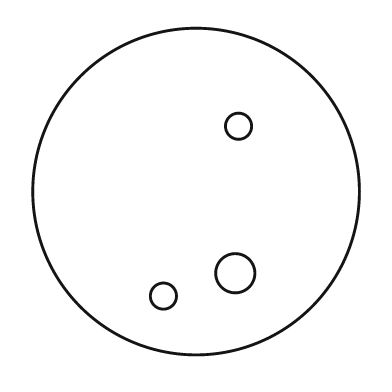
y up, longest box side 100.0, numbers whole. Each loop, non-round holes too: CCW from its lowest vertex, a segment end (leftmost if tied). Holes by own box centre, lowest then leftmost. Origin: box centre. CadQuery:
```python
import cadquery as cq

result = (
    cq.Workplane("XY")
    .moveTo(0.0, 0.0)
    .circle(50.0)
    .moveTo(-10.0, -32.0)
    .circle(4.0)
    .moveTo(12.0, -25.0)
    .circle(6.0)
    .moveTo(13.0, 20.0)
    .circle(4.0)
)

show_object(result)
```